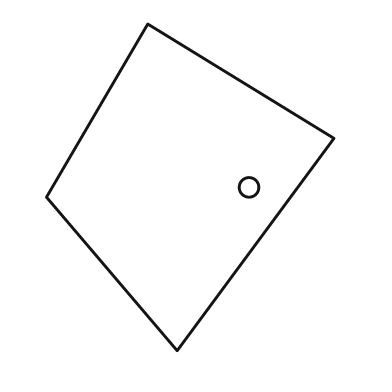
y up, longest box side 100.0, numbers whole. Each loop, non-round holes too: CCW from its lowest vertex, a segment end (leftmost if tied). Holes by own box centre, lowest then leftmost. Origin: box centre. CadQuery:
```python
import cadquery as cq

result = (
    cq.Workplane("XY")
    .moveTo(-4.0, -50.0)
    .lineTo(44.0, 15.0)
    .lineTo(-13.0, 50.0)
    .lineTo(-44.0, -3.0)
    .close()
    .moveTo(18.0, 0.0)
    .circle(3.0)
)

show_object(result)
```